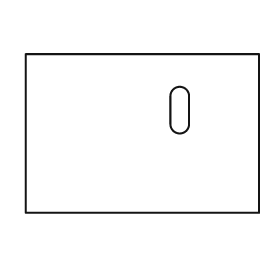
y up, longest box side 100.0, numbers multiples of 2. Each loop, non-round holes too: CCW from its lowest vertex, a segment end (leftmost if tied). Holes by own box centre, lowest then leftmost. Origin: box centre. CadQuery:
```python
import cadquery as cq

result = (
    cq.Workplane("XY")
    .moveTo(-50.0, -34.0)
    .lineTo(50.0, -34.0)
    .lineTo(50.0, 34.0)
    .lineTo(-50.0, 34.0)
    .close()
    .moveTo(12.0, 4.0)
    .threePointArc((16.0, 0.0), (20.0, 4.0))
    .lineTo(20.0, 16.0)
    .threePointArc((16.0, 20.0), (12.0, 16.0))
    .close()
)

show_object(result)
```